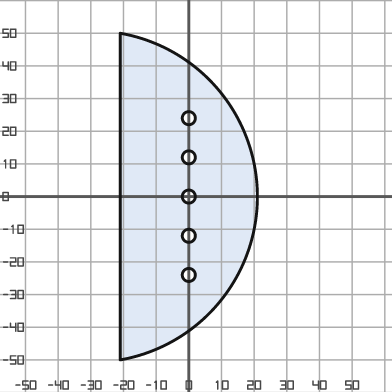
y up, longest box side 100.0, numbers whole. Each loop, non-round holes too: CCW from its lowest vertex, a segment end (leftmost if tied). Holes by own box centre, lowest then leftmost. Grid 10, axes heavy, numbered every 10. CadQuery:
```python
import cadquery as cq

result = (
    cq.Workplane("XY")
    .moveTo(-21.0, -50.0)
    .threePointArc((21.0, 0.0), (-21.0, 50.0))
    .close()
    .moveTo(0.0, -24.0)
    .circle(2.0)
    .moveTo(0.0, -12.0)
    .circle(2.0)
    .moveTo(0.0, 0.0)
    .circle(2.0)
    .moveTo(0.0, 12.0)
    .circle(2.0)
    .moveTo(0.0, 24.0)
    .circle(2.0)
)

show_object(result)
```